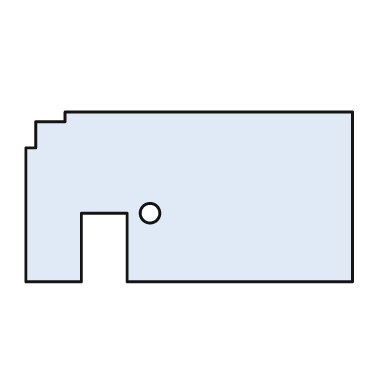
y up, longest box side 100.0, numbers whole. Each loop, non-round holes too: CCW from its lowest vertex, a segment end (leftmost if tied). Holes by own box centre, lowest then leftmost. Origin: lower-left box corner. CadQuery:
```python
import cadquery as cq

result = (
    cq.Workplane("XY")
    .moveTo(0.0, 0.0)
    .lineTo(17.0, 0.0)
    .lineTo(17.0, 21.0)
    .lineTo(31.0, 21.0)
    .lineTo(31.0, 0.0)
    .lineTo(100.0, 0.0)
    .lineTo(100.0, 52.0)
    .lineTo(12.0, 52.0)
    .lineTo(12.0, 49.0)
    .lineTo(3.0, 49.0)
    .lineTo(3.0, 41.0)
    .lineTo(0.0, 41.0)
    .close()
    .moveTo(38.0, 21.0)
    .circle(3.0)
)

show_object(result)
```